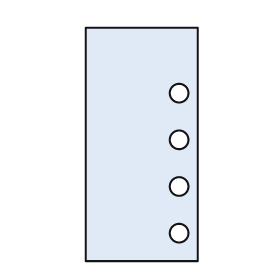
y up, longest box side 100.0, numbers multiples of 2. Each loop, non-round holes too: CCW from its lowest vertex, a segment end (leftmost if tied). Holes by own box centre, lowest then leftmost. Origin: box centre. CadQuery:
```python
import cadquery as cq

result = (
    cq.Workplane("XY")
    .moveTo(-24.0, -50.0)
    .lineTo(24.0, -50.0)
    .lineTo(24.0, 50.0)
    .lineTo(-24.0, 50.0)
    .close()
    .moveTo(16.0, -38.0)
    .circle(4.0)
    .moveTo(16.0, -18.0)
    .circle(4.0)
    .moveTo(16.0, 2.0)
    .circle(4.0)
    .moveTo(16.0, 22.0)
    .circle(4.0)
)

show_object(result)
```